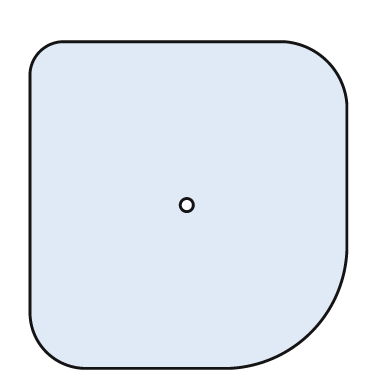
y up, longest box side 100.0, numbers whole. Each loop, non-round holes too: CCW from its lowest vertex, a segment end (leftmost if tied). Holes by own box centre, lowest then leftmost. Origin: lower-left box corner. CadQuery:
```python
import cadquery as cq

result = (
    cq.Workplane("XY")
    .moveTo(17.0, 0.0)
    .lineTo(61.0, 0.0)
    .threePointArc((86.0, 11.0), (97.0, 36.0))
    .lineTo(97.0, 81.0)
    .threePointArc((91.0, 94.0), (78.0, 100.0))
    .lineTo(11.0, 100.0)
    .threePointArc((3.0, 97.0), (0.0, 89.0))
    .lineTo(0.0, 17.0)
    .threePointArc((5.0, 5.0), (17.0, 0.0))
    .close()
    .moveTo(48.0, 50.0)
    .circle(2.0)
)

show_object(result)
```